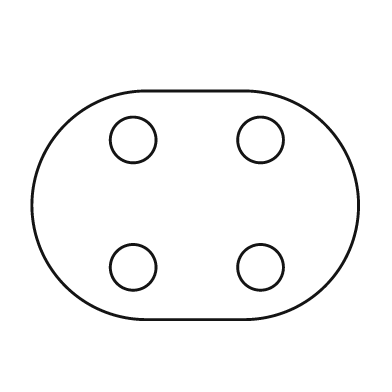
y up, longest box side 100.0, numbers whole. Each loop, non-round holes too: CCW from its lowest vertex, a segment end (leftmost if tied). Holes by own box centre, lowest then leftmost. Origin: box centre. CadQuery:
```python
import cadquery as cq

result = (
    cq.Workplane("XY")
    .moveTo(-15.0, -35.0)
    .lineTo(15.0, -35.0)
    .threePointArc((50.0, 0.0), (15.0, 35.0))
    .lineTo(-15.0, 35.0)
    .threePointArc((-50.0, 0.0), (-15.0, -35.0))
    .close()
    .moveTo(-19.0, -19.0)
    .circle(7.0)
    .moveTo(20.0, -19.0)
    .circle(7.0)
    .moveTo(-19.0, 20.0)
    .circle(7.0)
    .moveTo(20.0, 20.0)
    .circle(7.0)
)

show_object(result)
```